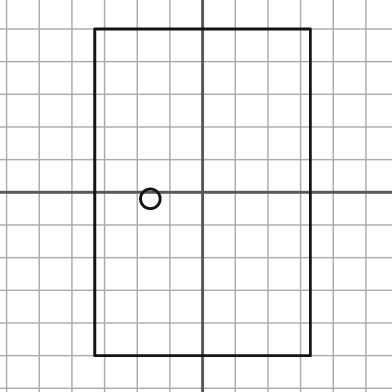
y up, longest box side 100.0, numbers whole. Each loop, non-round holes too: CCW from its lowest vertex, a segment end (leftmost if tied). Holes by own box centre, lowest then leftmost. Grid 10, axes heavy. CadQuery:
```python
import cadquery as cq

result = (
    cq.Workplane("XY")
    .moveTo(-33.0, -50.0)
    .lineTo(33.0, -50.0)
    .lineTo(33.0, 50.0)
    .lineTo(-33.0, 50.0)
    .close()
    .moveTo(-16.0, -2.0)
    .circle(3.0)
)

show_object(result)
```